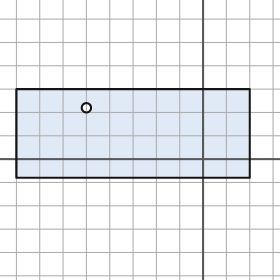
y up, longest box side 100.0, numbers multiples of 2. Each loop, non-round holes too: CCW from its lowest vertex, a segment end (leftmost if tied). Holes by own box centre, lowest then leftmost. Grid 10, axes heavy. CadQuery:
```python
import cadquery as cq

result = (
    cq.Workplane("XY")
    .moveTo(-80.0, -8.0)
    .lineTo(20.0, -8.0)
    .lineTo(20.0, 30.0)
    .lineTo(-80.0, 30.0)
    .close()
    .moveTo(-50.0, 22.0)
    .circle(2.0)
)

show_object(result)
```